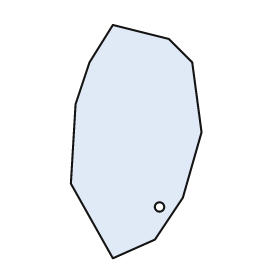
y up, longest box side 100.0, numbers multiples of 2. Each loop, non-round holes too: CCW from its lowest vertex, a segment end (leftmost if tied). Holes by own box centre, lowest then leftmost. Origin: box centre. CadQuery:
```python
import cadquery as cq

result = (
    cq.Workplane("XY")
    .moveTo(-10.0, -50.0)
    .lineTo(8.0, -42.0)
    .lineTo(20.0, -24.0)
    .lineTo(28.0, 4.0)
    .lineTo(24.0, 34.0)
    .lineTo(14.0, 44.0)
    .lineTo(-10.0, 50.0)
    .lineTo(-20.0, 34.0)
    .lineTo(-26.0, 16.0)
    .lineTo(-28.0, -18.0)
    .close()
    .moveTo(10.0, -28.0)
    .circle(2.0)
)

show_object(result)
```